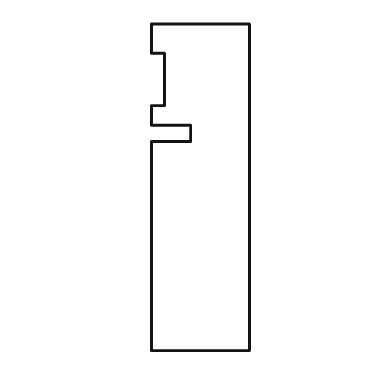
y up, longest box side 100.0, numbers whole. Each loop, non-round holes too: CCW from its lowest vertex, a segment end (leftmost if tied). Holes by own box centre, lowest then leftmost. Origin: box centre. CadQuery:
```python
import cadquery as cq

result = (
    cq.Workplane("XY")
    .moveTo(-15.0, -50.0)
    .lineTo(15.0, -50.0)
    .lineTo(15.0, 50.0)
    .lineTo(-15.0, 50.0)
    .lineTo(-15.0, 41.0)
    .lineTo(-11.0, 41.0)
    .lineTo(-11.0, 25.0)
    .lineTo(-15.0, 25.0)
    .lineTo(-15.0, 19.0)
    .lineTo(-3.0, 19.0)
    .lineTo(-3.0, 14.0)
    .lineTo(-15.0, 14.0)
    .close()
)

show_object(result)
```